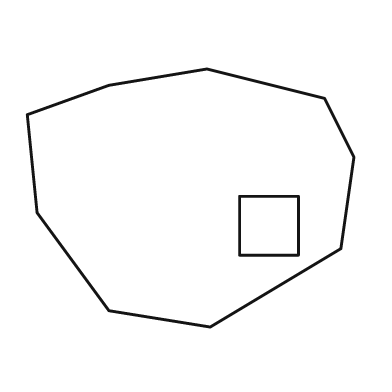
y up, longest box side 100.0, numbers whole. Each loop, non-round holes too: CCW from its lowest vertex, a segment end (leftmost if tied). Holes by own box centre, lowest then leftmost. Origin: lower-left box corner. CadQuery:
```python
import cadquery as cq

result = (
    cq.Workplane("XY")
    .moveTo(56.0, 0.0)
    .lineTo(96.0, 24.0)
    .lineTo(100.0, 52.0)
    .lineTo(91.0, 70.0)
    .lineTo(55.0, 79.0)
    .lineTo(25.0, 74.0)
    .lineTo(0.0, 65.0)
    .lineTo(3.0, 35.0)
    .lineTo(25.0, 5.0)
    .close()
    .moveTo(65.0, 22.0)
    .lineTo(83.0, 22.0)
    .lineTo(83.0, 40.0)
    .lineTo(65.0, 40.0)
    .close()
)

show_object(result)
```